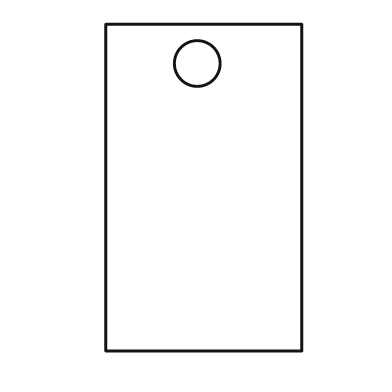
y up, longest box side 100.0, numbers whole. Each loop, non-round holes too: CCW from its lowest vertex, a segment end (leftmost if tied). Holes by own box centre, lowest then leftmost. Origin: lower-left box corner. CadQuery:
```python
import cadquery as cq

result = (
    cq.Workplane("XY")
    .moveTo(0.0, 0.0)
    .lineTo(60.0, 0.0)
    .lineTo(60.0, 100.0)
    .lineTo(0.0, 100.0)
    .close()
    .moveTo(28.0, 88.0)
    .circle(7.0)
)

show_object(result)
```